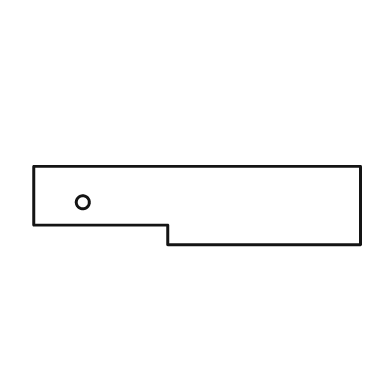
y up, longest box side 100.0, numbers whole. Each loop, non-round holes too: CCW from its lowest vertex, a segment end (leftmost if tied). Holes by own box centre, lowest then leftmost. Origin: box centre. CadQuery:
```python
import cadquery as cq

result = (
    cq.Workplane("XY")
    .moveTo(-9.0, -12.0)
    .lineTo(50.0, -12.0)
    .lineTo(50.0, 12.0)
    .lineTo(-50.0, 12.0)
    .lineTo(-50.0, -6.0)
    .lineTo(-9.0, -6.0)
    .close()
    .moveTo(-35.0, 1.0)
    .circle(2.0)
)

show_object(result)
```